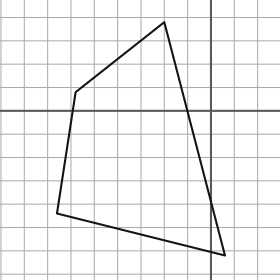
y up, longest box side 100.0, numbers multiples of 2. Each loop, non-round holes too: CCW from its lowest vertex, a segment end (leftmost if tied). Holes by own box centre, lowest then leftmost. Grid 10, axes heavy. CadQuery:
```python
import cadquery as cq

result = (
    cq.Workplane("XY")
    .moveTo(6.0, -62.0)
    .lineTo(-20.0, 38.0)
    .lineTo(-58.0, 8.0)
    .lineTo(-66.0, -44.0)
    .close()
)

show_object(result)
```